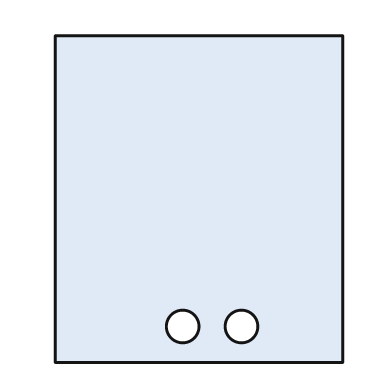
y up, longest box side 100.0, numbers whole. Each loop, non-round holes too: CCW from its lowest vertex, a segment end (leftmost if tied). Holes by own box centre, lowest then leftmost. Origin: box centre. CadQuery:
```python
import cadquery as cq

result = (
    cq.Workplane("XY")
    .moveTo(-44.0, -50.0)
    .lineTo(44.0, -50.0)
    .lineTo(44.0, 50.0)
    .lineTo(-44.0, 50.0)
    .close()
    .moveTo(-5.0, -39.0)
    .circle(5.0)
    .moveTo(13.0, -39.0)
    .circle(5.0)
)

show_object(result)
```